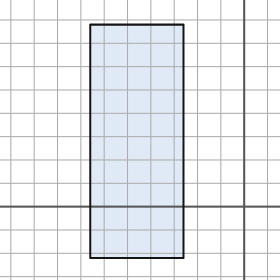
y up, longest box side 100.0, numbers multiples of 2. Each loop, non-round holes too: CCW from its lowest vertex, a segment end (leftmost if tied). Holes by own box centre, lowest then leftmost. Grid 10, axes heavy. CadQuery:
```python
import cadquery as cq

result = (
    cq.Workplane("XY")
    .moveTo(-66.0, -22.0)
    .lineTo(-26.0, -22.0)
    .lineTo(-26.0, 78.0)
    .lineTo(-66.0, 78.0)
    .close()
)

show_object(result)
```